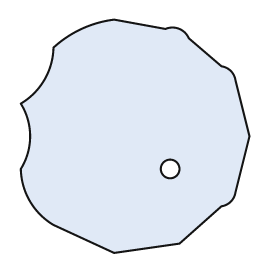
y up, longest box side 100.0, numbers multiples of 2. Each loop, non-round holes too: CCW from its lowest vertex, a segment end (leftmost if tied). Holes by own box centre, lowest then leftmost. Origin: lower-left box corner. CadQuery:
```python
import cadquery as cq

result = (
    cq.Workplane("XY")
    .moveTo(40.0, 0.0)
    .lineTo(68.0, 4.0)
    .lineTo(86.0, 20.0)
    .threePointArc((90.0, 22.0), (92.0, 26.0))
    .lineTo(98.0, 50.0)
    .lineTo(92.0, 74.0)
    .threePointArc((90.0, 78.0), (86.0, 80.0))
    .lineTo(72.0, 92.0)
    .threePointArc((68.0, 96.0), (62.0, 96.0))
    .lineTo(40.0, 100.0)
    .threePointArc((26.0, 96.0), (14.0, 88.0))
    .threePointArc((10.0, 74.0), (0.0, 64.0))
    .threePointArc((4.0, 50.0), (0.0, 36.0))
    .threePointArc((4.0, 22.0), (14.0, 12.0))
    .close()
    .moveTo(64.0, 36.0)
    .circle(4.0)
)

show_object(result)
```